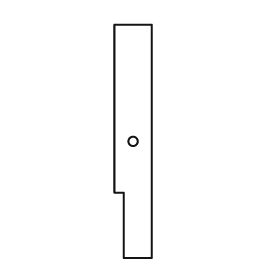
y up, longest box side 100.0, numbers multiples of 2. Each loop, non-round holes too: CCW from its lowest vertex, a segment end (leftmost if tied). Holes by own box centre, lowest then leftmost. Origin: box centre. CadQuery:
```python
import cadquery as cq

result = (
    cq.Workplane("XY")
    .moveTo(-4.0, -50.0)
    .lineTo(8.0, -50.0)
    .lineTo(8.0, 50.0)
    .lineTo(-8.0, 50.0)
    .lineTo(-8.0, -22.0)
    .lineTo(-4.0, -22.0)
    .close()
    .moveTo(0.0, 0.0)
    .circle(2.0)
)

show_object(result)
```